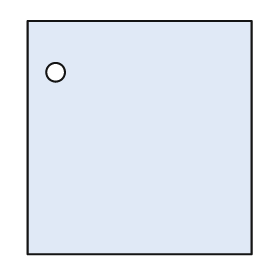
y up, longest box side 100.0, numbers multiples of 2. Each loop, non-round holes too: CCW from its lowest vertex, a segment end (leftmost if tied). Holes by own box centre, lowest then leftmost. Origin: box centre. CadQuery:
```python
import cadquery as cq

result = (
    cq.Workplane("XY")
    .moveTo(-48.0, -50.0)
    .lineTo(48.0, -50.0)
    .lineTo(48.0, 50.0)
    .lineTo(-48.0, 50.0)
    .close()
    .moveTo(-36.0, 28.0)
    .circle(4.0)
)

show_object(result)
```